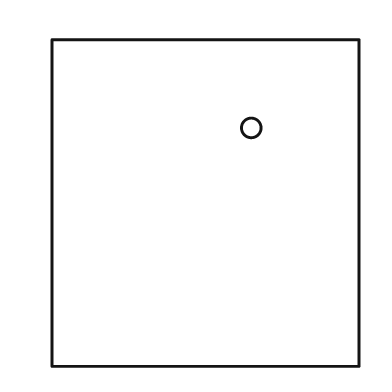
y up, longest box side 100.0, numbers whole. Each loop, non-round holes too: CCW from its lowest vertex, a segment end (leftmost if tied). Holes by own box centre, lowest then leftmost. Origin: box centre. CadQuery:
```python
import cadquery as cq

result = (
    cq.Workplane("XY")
    .moveTo(-47.0, -50.0)
    .lineTo(47.0, -50.0)
    .lineTo(47.0, 50.0)
    .lineTo(-47.0, 50.0)
    .close()
    .moveTo(14.0, 23.0)
    .circle(3.0)
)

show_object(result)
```